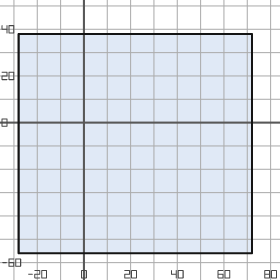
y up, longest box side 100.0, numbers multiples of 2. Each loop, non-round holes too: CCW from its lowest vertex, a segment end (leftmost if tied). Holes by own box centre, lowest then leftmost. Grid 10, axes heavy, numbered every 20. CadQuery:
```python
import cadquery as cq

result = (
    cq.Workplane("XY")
    .moveTo(-28.0, -56.0)
    .lineTo(72.0, -56.0)
    .lineTo(72.0, 38.0)
    .lineTo(-28.0, 38.0)
    .close()
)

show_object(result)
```